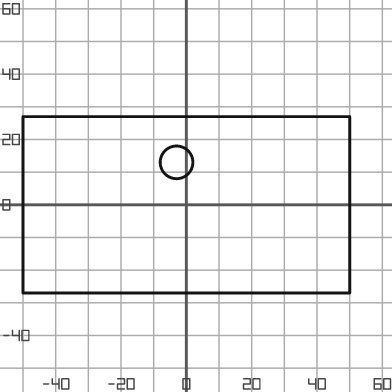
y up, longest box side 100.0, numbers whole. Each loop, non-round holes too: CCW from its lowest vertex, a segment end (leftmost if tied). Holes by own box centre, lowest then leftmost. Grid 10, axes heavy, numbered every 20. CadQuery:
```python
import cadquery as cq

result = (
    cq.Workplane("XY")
    .moveTo(-50.0, -27.0)
    .lineTo(50.0, -27.0)
    .lineTo(50.0, 27.0)
    .lineTo(-50.0, 27.0)
    .close()
    .moveTo(-3.0, 13.0)
    .circle(5.0)
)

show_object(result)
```